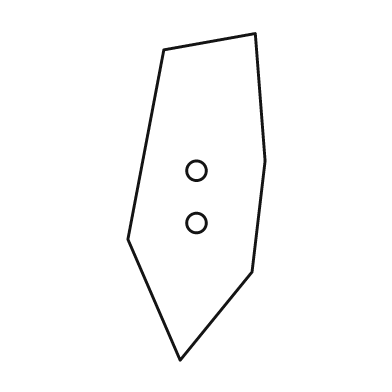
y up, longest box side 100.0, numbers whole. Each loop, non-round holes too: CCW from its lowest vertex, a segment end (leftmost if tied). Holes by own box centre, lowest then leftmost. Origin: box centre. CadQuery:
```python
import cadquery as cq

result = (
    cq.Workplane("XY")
    .moveTo(-5.0, -50.0)
    .lineTo(17.0, -23.0)
    .lineTo(21.0, 11.0)
    .lineTo(18.0, 50.0)
    .lineTo(-10.0, 45.0)
    .lineTo(-21.0, -13.0)
    .close()
    .moveTo(0.0, -8.0)
    .circle(3.0)
    .moveTo(0.0, 8.0)
    .circle(3.0)
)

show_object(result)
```